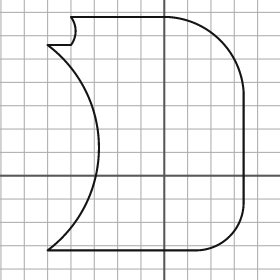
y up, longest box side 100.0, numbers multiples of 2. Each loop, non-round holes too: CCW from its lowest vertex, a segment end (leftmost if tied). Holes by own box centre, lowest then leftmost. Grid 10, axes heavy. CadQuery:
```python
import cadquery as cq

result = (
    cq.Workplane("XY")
    .moveTo(-50.0, -32.0)
    .lineTo(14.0, -32.0)
    .threePointArc((28.0, -26.0), (34.0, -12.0))
    .lineTo(34.0, 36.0)
    .threePointArc((24.0, 58.0), (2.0, 68.0))
    .lineTo(-40.0, 68.0)
    .threePointArc((-38.0, 62.0), (-40.0, 56.0))
    .lineTo(-50.0, 56.0)
    .threePointArc((-28.0, 12.0), (-50.0, -32.0))
    .close()
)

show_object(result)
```